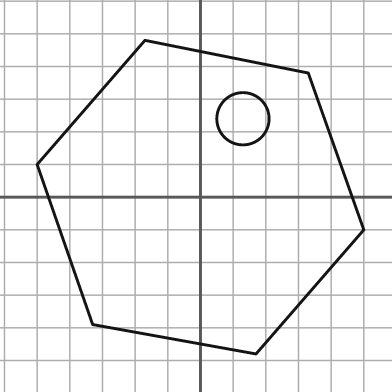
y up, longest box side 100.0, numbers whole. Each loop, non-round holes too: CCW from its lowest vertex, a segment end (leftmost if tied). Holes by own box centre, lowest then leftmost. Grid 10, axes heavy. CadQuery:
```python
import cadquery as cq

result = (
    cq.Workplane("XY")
    .moveTo(17.0, -48.0)
    .lineTo(50.0, -10.0)
    .lineTo(33.0, 38.0)
    .lineTo(-17.0, 48.0)
    .lineTo(-50.0, 10.0)
    .lineTo(-33.0, -39.0)
    .close()
    .moveTo(13.0, 24.0)
    .circle(8.0)
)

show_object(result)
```